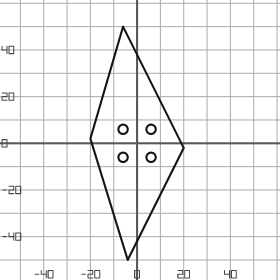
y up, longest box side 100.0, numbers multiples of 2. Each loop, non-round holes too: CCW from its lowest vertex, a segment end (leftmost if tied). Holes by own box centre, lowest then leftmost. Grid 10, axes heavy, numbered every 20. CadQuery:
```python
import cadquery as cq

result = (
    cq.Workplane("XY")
    .moveTo(-4.0, -50.0)
    .lineTo(20.0, -2.0)
    .lineTo(-6.0, 50.0)
    .lineTo(-20.0, 2.0)
    .close()
    .moveTo(-6.0, -6.0)
    .circle(2.0)
    .moveTo(6.0, -6.0)
    .circle(2.0)
    .moveTo(-6.0, 6.0)
    .circle(2.0)
    .moveTo(6.0, 6.0)
    .circle(2.0)
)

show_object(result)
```